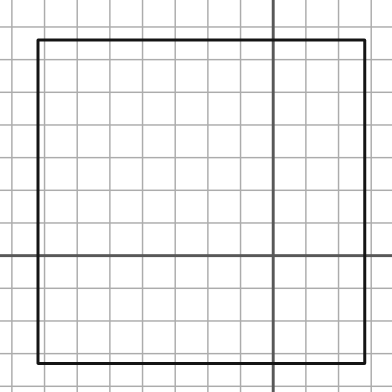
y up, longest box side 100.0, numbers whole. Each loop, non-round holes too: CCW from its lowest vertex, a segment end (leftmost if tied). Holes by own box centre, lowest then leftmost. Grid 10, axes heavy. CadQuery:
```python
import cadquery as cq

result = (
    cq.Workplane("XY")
    .moveTo(-72.0, -33.0)
    .lineTo(28.0, -33.0)
    .lineTo(28.0, 66.0)
    .lineTo(-72.0, 66.0)
    .close()
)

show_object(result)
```